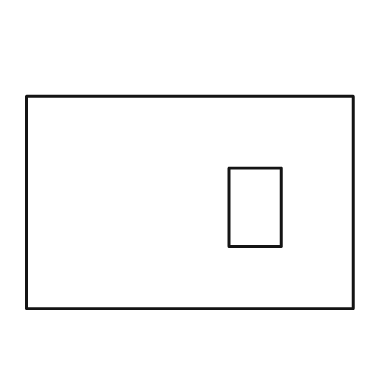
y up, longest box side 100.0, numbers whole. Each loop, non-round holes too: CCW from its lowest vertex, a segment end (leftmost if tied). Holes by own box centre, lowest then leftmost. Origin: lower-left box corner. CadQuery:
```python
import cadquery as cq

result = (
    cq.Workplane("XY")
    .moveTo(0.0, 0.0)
    .lineTo(100.0, 0.0)
    .lineTo(100.0, 65.0)
    .lineTo(0.0, 65.0)
    .close()
    .moveTo(62.0, 19.0)
    .lineTo(78.0, 19.0)
    .lineTo(78.0, 43.0)
    .lineTo(62.0, 43.0)
    .close()
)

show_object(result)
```